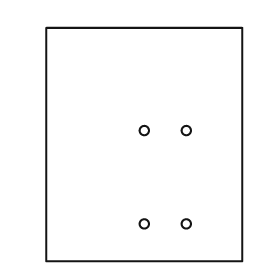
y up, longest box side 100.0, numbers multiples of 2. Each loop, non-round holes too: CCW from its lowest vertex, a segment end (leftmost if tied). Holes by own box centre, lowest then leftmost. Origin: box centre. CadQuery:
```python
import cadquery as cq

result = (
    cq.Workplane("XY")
    .moveTo(-42.0, -50.0)
    .lineTo(42.0, -50.0)
    .lineTo(42.0, 50.0)
    .lineTo(-42.0, 50.0)
    .close()
    .moveTo(0.0, -34.0)
    .circle(2.0)
    .moveTo(18.0, -34.0)
    .circle(2.0)
    .moveTo(0.0, 6.0)
    .circle(2.0)
    .moveTo(18.0, 6.0)
    .circle(2.0)
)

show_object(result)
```